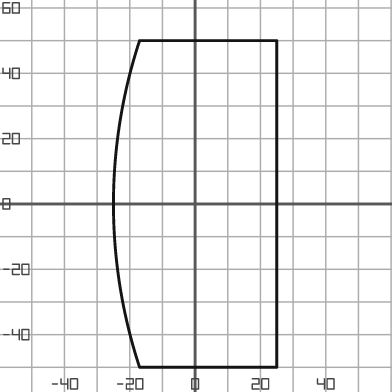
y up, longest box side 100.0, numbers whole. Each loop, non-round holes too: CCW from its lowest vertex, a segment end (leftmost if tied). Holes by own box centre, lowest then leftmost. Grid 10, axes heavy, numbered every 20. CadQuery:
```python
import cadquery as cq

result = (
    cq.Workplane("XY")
    .moveTo(-17.0, -50.0)
    .lineTo(25.0, -50.0)
    .lineTo(25.0, 50.0)
    .lineTo(-17.0, 50.0)
    .threePointArc((-25.0, 0.0), (-17.0, -50.0))
    .close()
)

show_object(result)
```